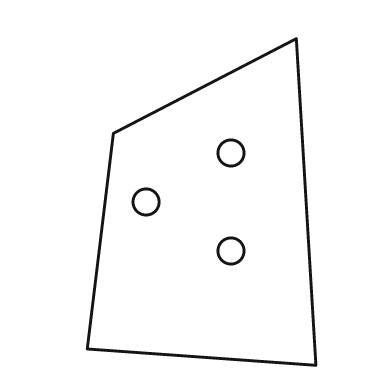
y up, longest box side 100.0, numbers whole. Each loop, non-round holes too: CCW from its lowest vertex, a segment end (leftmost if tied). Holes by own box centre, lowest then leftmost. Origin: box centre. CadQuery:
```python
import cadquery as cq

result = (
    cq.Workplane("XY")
    .moveTo(35.0, -50.0)
    .lineTo(29.0, 50.0)
    .lineTo(-27.0, 21.0)
    .lineTo(-35.0, -45.0)
    .close()
    .moveTo(9.0, -15.0)
    .circle(4.0)
    .moveTo(-17.0, 0.0)
    .circle(4.0)
    .moveTo(9.0, 15.0)
    .circle(4.0)
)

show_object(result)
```